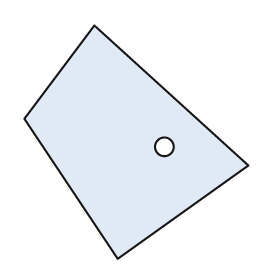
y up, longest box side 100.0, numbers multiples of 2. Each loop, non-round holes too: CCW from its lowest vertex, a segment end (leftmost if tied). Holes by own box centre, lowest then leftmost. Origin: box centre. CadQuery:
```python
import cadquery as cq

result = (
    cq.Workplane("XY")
    .moveTo(-8.0, -50.0)
    .lineTo(48.0, -10.0)
    .lineTo(-18.0, 50.0)
    .lineTo(-48.0, 10.0)
    .close()
    .moveTo(12.0, -2.0)
    .circle(4.0)
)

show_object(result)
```